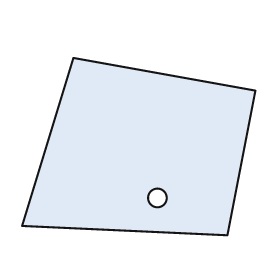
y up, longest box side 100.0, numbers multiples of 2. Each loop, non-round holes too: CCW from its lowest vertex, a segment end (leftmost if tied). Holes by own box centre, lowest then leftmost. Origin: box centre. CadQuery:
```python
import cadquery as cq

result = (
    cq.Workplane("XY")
    .moveTo(38.0, -38.0)
    .lineTo(50.0, 24.0)
    .lineTo(-28.0, 38.0)
    .lineTo(-50.0, -34.0)
    .close()
    .moveTo(8.0, -22.0)
    .circle(4.0)
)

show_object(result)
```